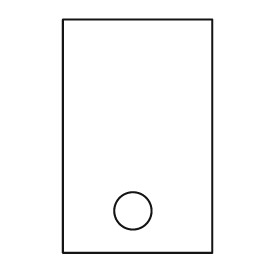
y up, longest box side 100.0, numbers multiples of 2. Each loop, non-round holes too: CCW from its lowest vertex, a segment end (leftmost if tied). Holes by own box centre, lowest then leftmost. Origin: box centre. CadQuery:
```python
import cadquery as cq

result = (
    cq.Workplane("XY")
    .moveTo(-32.0, -50.0)
    .lineTo(32.0, -50.0)
    .lineTo(32.0, 50.0)
    .lineTo(-32.0, 50.0)
    .close()
    .moveTo(-2.0, -32.0)
    .circle(8.0)
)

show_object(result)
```